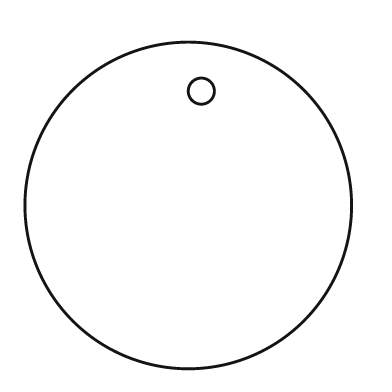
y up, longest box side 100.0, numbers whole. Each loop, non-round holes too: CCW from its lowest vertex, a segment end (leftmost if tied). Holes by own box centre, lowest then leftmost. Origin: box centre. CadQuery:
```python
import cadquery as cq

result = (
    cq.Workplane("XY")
    .moveTo(0.0, 0.0)
    .circle(50.0)
    .moveTo(4.0, 35.0)
    .circle(4.0)
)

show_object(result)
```